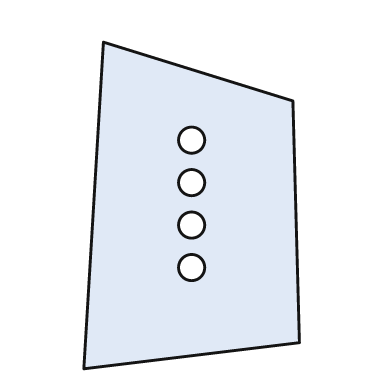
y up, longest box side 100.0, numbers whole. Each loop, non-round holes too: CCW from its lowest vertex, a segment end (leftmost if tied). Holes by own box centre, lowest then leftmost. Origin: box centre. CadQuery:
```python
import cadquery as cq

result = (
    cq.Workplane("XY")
    .moveTo(-33.0, -50.0)
    .lineTo(33.0, -42.0)
    .lineTo(31.0, 32.0)
    .lineTo(-27.0, 50.0)
    .close()
    .moveTo(0.0, -19.0)
    .circle(4.0)
    .moveTo(0.0, -6.0)
    .circle(4.0)
    .moveTo(0.0, 7.0)
    .circle(4.0)
    .moveTo(0.0, 20.0)
    .circle(4.0)
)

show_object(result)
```